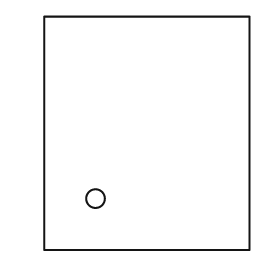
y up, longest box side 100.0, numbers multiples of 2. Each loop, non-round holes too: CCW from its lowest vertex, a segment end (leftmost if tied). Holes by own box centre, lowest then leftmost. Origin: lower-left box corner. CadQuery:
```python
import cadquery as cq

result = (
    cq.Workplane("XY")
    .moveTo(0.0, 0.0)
    .lineTo(88.0, 0.0)
    .lineTo(88.0, 100.0)
    .lineTo(0.0, 100.0)
    .close()
    .moveTo(22.0, 22.0)
    .circle(4.0)
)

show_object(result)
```